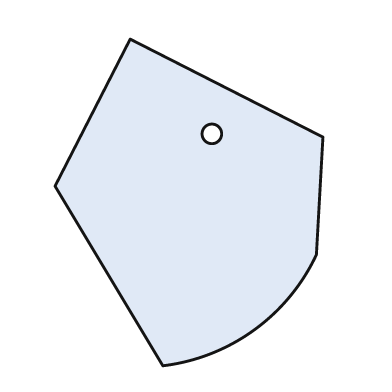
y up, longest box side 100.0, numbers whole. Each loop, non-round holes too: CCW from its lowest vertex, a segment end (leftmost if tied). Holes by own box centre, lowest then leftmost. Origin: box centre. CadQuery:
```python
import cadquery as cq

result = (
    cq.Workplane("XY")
    .moveTo(-8.0, -50.0)
    .threePointArc((20.0, -39.0), (39.0, -16.0))
    .lineTo(41.0, 20.0)
    .lineTo(-18.0, 50.0)
    .lineTo(-41.0, 5.0)
    .close()
    .moveTo(7.0, 21.0)
    .circle(3.0)
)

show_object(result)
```